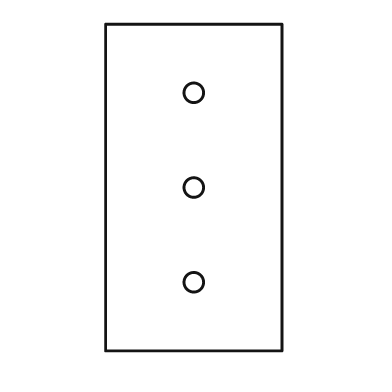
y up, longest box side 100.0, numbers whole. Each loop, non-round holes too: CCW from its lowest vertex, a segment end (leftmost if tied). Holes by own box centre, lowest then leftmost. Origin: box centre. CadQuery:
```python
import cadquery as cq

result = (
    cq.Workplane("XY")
    .moveTo(-27.0, -50.0)
    .lineTo(27.0, -50.0)
    .lineTo(27.0, 50.0)
    .lineTo(-27.0, 50.0)
    .close()
    .moveTo(0.0, -29.0)
    .circle(3.0)
    .moveTo(0.0, 0.0)
    .circle(3.0)
    .moveTo(0.0, 29.0)
    .circle(3.0)
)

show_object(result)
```